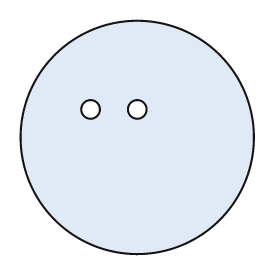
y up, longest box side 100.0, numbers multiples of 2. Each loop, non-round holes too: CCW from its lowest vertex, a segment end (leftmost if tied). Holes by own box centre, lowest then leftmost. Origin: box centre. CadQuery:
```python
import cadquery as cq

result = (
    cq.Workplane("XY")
    .moveTo(0.0, 0.0)
    .circle(50.0)
    .moveTo(-20.0, 12.0)
    .circle(4.0)
    .moveTo(0.0, 12.0)
    .circle(4.0)
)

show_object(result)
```